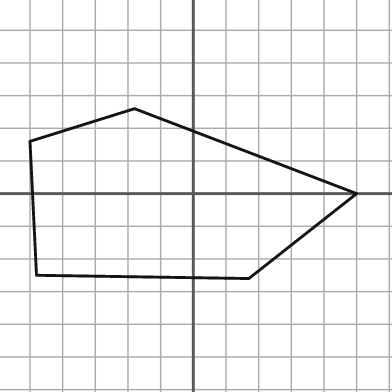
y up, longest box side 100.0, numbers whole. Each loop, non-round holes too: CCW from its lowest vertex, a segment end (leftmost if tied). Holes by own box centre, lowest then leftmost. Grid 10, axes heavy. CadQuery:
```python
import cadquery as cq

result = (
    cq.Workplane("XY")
    .moveTo(17.0, -26.0)
    .lineTo(50.0, 0.0)
    .lineTo(-18.0, 26.0)
    .lineTo(-50.0, 16.0)
    .lineTo(-48.0, -25.0)
    .close()
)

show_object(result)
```